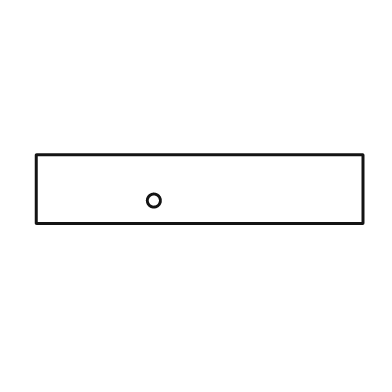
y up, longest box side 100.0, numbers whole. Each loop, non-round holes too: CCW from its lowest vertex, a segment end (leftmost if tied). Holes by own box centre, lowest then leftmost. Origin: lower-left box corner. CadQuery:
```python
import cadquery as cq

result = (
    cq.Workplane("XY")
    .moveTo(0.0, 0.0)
    .lineTo(100.0, 0.0)
    .lineTo(100.0, 21.0)
    .lineTo(0.0, 21.0)
    .close()
    .moveTo(36.0, 7.0)
    .circle(2.0)
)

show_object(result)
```